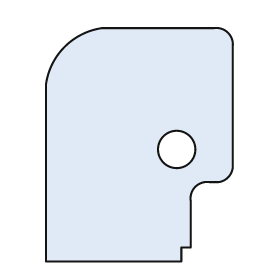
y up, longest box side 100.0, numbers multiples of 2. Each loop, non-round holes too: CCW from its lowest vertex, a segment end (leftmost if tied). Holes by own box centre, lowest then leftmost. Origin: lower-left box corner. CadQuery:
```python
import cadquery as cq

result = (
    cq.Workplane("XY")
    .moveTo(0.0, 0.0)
    .lineTo(58.0, 0.0)
    .lineTo(58.0, 6.0)
    .lineTo(62.0, 6.0)
    .lineTo(62.0, 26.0)
    .threePointArc((64.0, 32.0), (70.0, 34.0))
    .lineTo(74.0, 34.0)
    .threePointArc((78.0, 36.0), (80.0, 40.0))
    .lineTo(80.0, 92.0)
    .threePointArc((78.0, 98.0), (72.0, 100.0))
    .lineTo(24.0, 100.0)
    .threePointArc((8.0, 92.0), (0.0, 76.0))
    .close()
    .moveTo(56.0, 48.0)
    .circle(8.0)
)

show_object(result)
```